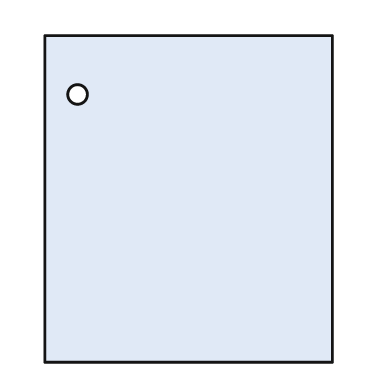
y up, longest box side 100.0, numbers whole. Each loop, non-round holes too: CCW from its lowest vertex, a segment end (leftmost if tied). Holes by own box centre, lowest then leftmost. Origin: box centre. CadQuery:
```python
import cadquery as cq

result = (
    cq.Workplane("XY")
    .moveTo(-44.0, -50.0)
    .lineTo(44.0, -50.0)
    .lineTo(44.0, 50.0)
    .lineTo(-44.0, 50.0)
    .close()
    .moveTo(-34.0, 32.0)
    .circle(3.0)
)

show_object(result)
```